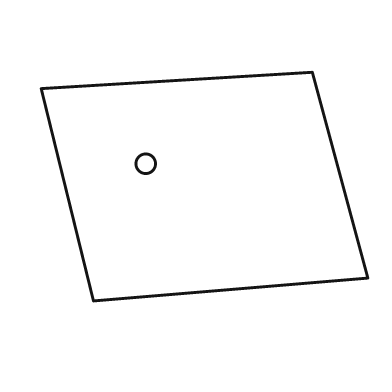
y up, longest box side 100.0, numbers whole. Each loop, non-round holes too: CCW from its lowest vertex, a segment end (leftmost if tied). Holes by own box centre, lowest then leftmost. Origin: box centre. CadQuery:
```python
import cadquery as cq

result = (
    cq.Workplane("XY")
    .moveTo(-34.0, -35.0)
    .lineTo(50.0, -28.0)
    .lineTo(33.0, 35.0)
    .lineTo(-50.0, 30.0)
    .close()
    .moveTo(-18.0, 7.0)
    .circle(3.0)
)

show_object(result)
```